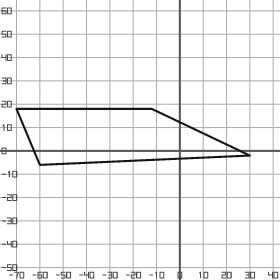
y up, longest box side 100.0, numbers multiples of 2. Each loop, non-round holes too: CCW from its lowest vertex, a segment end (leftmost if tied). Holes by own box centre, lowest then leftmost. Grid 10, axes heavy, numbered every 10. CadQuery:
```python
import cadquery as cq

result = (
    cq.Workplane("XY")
    .moveTo(-60.0, -6.0)
    .lineTo(30.0, -2.0)
    .lineTo(-12.0, 18.0)
    .lineTo(-70.0, 18.0)
    .close()
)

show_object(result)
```